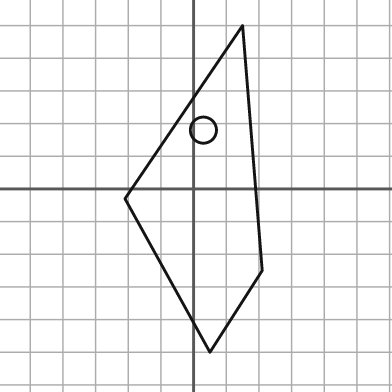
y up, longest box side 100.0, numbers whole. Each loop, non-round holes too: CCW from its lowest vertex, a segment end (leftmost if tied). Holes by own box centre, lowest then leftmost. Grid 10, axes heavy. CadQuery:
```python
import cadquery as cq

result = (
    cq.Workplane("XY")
    .moveTo(5.0, -50.0)
    .lineTo(21.0, -25.0)
    .lineTo(15.0, 50.0)
    .lineTo(-21.0, -3.0)
    .close()
    .moveTo(3.0, 18.0)
    .circle(4.0)
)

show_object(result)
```